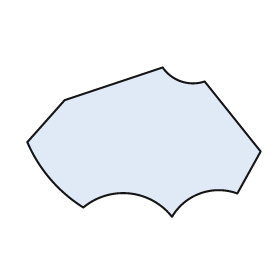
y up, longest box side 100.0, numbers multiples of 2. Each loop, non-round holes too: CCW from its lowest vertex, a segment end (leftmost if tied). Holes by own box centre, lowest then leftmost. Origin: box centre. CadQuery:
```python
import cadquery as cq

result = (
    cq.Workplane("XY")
    .moveTo(12.0, -32.0)
    .threePointArc((24.0, -22.0), (40.0, -22.0))
    .lineTo(50.0, -4.0)
    .lineTo(26.0, 26.0)
    .threePointArc((16.0, 26.0), (8.0, 32.0))
    .lineTo(-34.0, 18.0)
    .lineTo(-50.0, 0.0)
    .threePointArc((-40.0, -16.0), (-26.0, -28.0))
    .threePointArc((-6.0, -22.0), (12.0, -32.0))
    .close()
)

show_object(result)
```